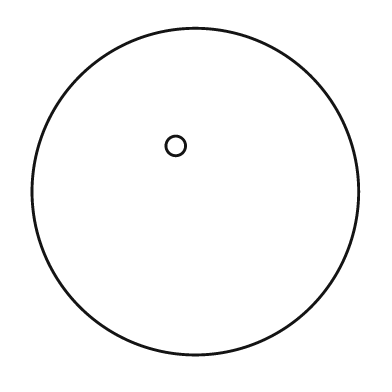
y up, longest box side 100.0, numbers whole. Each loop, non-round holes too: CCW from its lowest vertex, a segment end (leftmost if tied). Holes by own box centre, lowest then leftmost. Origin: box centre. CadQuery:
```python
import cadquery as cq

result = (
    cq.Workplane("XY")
    .moveTo(0.0, 0.0)
    .circle(50.0)
    .moveTo(-6.0, 14.0)
    .circle(3.0)
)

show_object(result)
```